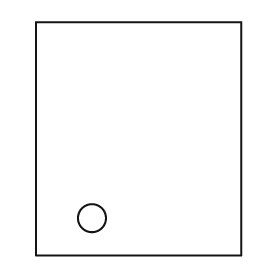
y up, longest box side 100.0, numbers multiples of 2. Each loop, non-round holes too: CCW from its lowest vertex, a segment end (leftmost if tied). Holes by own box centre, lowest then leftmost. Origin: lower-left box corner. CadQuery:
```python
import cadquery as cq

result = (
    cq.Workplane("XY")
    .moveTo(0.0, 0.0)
    .lineTo(88.0, 0.0)
    .lineTo(88.0, 100.0)
    .lineTo(0.0, 100.0)
    .close()
    .moveTo(24.0, 16.0)
    .circle(6.0)
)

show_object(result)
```